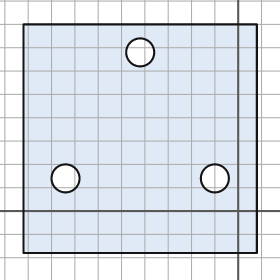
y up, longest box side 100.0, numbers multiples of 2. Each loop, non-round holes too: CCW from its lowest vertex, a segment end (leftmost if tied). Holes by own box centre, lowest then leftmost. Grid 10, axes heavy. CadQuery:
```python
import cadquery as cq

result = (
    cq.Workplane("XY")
    .moveTo(-92.0, -18.0)
    .lineTo(8.0, -18.0)
    .lineTo(8.0, 80.0)
    .lineTo(-92.0, 80.0)
    .close()
    .moveTo(-74.0, 14.0)
    .circle(6.0)
    .moveTo(-10.0, 14.0)
    .circle(6.0)
    .moveTo(-42.0, 68.0)
    .circle(6.0)
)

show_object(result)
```